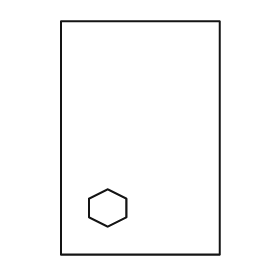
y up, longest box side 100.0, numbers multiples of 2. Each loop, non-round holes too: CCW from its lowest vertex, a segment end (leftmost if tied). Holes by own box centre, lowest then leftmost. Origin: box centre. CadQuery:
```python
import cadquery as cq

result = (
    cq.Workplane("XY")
    .moveTo(-34.0, -50.0)
    .lineTo(34.0, -50.0)
    .lineTo(34.0, 50.0)
    .lineTo(-34.0, 50.0)
    .close()
    .moveTo(-14.0, -38.0)
    .lineTo(-6.0, -34.0)
    .lineTo(-6.0, -26.0)
    .lineTo(-14.0, -22.0)
    .lineTo(-22.0, -26.0)
    .lineTo(-22.0, -34.0)
    .close()
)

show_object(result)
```